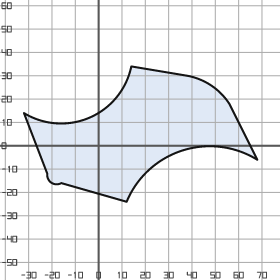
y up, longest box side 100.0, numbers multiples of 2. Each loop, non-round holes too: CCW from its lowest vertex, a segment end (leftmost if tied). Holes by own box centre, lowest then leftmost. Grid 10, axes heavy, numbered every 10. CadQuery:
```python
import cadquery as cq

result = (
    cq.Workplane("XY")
    .moveTo(12.0, -24.0)
    .threePointArc((36.0, -2.0), (68.0, -6.0))
    .lineTo(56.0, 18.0)
    .threePointArc((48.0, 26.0), (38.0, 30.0))
    .lineTo(14.0, 34.0)
    .threePointArc((-4.0, 12.0), (-32.0, 14.0))
    .lineTo(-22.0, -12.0)
    .threePointArc((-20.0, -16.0), (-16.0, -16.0))
    .close()
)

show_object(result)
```